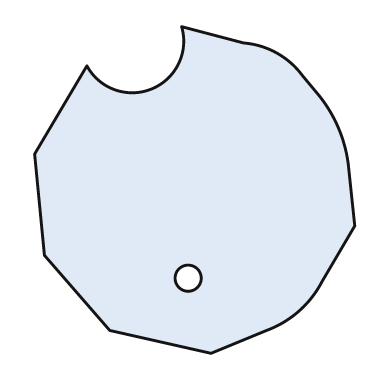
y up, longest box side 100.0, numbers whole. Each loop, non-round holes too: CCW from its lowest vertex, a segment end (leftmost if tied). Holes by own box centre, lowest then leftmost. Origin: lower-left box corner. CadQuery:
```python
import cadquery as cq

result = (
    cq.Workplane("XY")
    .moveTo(54.0, 0.0)
    .lineTo(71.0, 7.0)
    .threePointArc((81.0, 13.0), (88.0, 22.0))
    .lineTo(98.0, 39.0)
    .lineTo(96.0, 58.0)
    .threePointArc((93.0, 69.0), (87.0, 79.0))
    .lineTo(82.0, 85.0)
    .threePointArc((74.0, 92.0), (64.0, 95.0))
    .lineTo(45.0, 100.0)
    .threePointArc((36.0, 81.0), (16.0, 88.0))
    .lineTo(0.0, 61.0)
    .lineTo(3.0, 30.0)
    .lineTo(23.0, 7.0)
    .close()
    .moveTo(47.0, 23.0)
    .circle(4.0)
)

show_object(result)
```